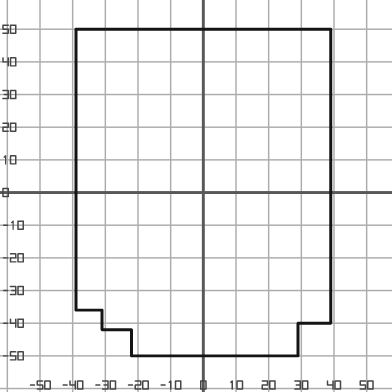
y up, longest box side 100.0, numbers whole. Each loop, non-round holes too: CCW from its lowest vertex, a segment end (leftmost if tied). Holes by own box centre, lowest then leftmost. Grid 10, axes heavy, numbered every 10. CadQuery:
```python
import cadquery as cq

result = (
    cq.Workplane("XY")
    .moveTo(-22.0, -50.0)
    .lineTo(29.0, -50.0)
    .lineTo(29.0, -40.0)
    .lineTo(39.0, -40.0)
    .lineTo(39.0, 50.0)
    .lineTo(-39.0, 50.0)
    .lineTo(-39.0, -36.0)
    .lineTo(-31.0, -36.0)
    .lineTo(-31.0, -42.0)
    .lineTo(-22.0, -42.0)
    .close()
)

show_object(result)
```